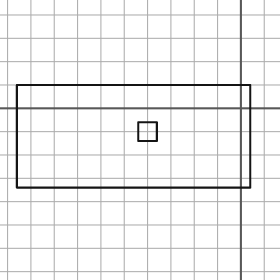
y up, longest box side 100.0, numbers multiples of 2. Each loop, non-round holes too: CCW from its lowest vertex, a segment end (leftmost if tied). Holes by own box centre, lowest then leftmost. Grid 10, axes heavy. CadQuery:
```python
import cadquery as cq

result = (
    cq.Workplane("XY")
    .moveTo(-96.0, -34.0)
    .lineTo(4.0, -34.0)
    .lineTo(4.0, 10.0)
    .lineTo(-96.0, 10.0)
    .close()
    .moveTo(-44.0, -14.0)
    .lineTo(-36.0, -14.0)
    .lineTo(-36.0, -6.0)
    .lineTo(-44.0, -6.0)
    .close()
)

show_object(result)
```